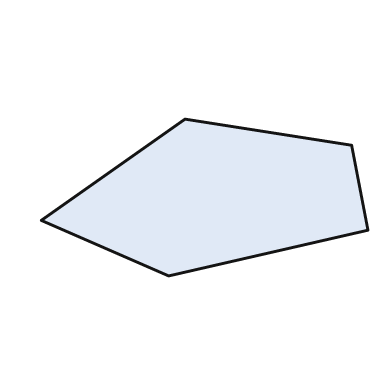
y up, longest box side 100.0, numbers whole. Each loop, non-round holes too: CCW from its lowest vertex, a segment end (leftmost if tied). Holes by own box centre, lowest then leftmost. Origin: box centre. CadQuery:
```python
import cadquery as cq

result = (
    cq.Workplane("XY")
    .moveTo(-11.0, -24.0)
    .lineTo(50.0, -10.0)
    .lineTo(45.0, 16.0)
    .lineTo(-6.0, 24.0)
    .lineTo(-50.0, -7.0)
    .close()
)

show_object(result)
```